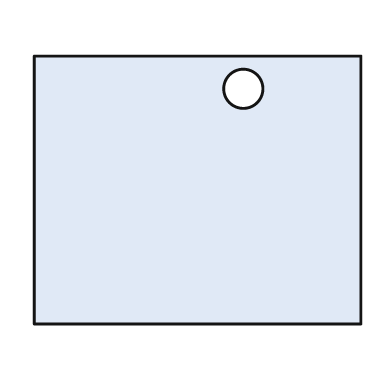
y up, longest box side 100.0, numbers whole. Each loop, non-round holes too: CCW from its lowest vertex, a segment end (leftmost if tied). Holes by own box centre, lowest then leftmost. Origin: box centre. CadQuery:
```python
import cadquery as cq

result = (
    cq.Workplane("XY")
    .moveTo(-50.0, -41.0)
    .lineTo(50.0, -41.0)
    .lineTo(50.0, 41.0)
    .lineTo(-50.0, 41.0)
    .close()
    .moveTo(14.0, 31.0)
    .circle(6.0)
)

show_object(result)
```